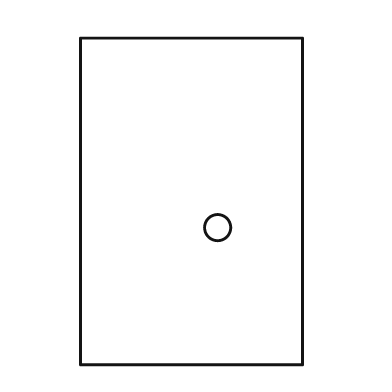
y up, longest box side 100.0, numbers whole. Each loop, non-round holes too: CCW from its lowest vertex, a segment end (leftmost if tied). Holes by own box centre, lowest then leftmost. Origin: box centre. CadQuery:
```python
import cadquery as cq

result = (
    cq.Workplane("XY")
    .moveTo(-34.0, -50.0)
    .lineTo(34.0, -50.0)
    .lineTo(34.0, 50.0)
    .lineTo(-34.0, 50.0)
    .close()
    .moveTo(8.0, -8.0)
    .circle(4.0)
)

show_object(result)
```